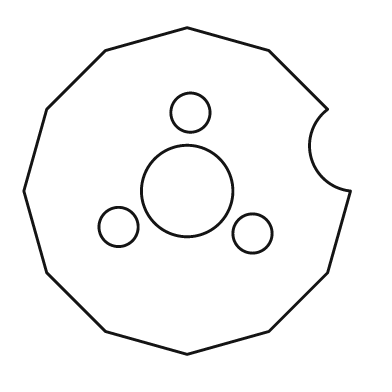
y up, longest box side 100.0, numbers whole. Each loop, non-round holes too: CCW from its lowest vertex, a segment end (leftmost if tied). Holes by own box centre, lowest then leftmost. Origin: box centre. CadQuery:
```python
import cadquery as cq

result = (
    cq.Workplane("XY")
    .moveTo(0.0, -50.0)
    .lineTo(25.0, -43.0)
    .lineTo(43.0, -25.0)
    .lineTo(50.0, 0.0)
    .threePointArc((38.0, 10.0), (43.0, 25.0))
    .lineTo(25.0, 43.0)
    .lineTo(0.0, 50.0)
    .lineTo(-25.0, 43.0)
    .lineTo(-43.0, 25.0)
    .lineTo(-50.0, 0.0)
    .lineTo(-43.0, -25.0)
    .lineTo(-25.0, -43.0)
    .close()
    .moveTo(20.0, -13.0)
    .circle(6.0)
    .moveTo(-21.0, -11.0)
    .circle(6.0)
    .moveTo(0.0, 0.0)
    .circle(14.0)
    .moveTo(1.0, 24.0)
    .circle(6.0)
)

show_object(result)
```